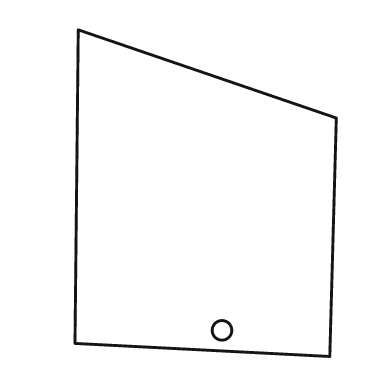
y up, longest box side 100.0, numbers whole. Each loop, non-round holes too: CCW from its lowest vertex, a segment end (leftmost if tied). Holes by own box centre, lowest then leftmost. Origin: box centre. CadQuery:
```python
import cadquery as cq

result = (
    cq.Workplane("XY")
    .moveTo(38.0, -50.0)
    .lineTo(40.0, 23.0)
    .lineTo(-39.0, 50.0)
    .lineTo(-40.0, -46.0)
    .close()
    .moveTo(5.0, -42.0)
    .circle(3.0)
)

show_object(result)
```